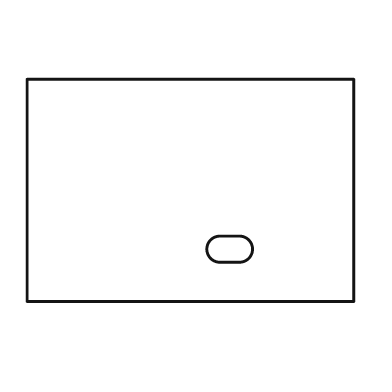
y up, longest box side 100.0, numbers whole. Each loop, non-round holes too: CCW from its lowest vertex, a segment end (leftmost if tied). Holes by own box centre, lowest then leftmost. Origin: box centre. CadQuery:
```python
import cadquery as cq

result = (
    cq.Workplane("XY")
    .moveTo(-50.0, -34.0)
    .lineTo(50.0, -34.0)
    .lineTo(50.0, 34.0)
    .lineTo(-50.0, 34.0)
    .close()
    .moveTo(9.0, -22.0)
    .lineTo(15.0, -22.0)
    .threePointArc((19.0, -18.0), (15.0, -14.0))
    .lineTo(9.0, -14.0)
    .threePointArc((5.0, -18.0), (9.0, -22.0))
    .close()
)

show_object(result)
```